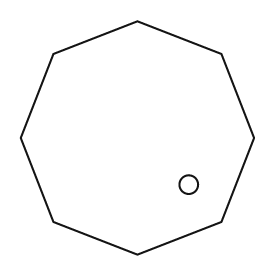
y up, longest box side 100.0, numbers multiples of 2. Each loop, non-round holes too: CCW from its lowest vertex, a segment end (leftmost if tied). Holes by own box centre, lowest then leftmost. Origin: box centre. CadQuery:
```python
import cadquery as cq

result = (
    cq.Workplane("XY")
    .moveTo(0.0, -50.0)
    .lineTo(36.0, -36.0)
    .lineTo(50.0, 0.0)
    .lineTo(36.0, 36.0)
    .lineTo(0.0, 50.0)
    .lineTo(-36.0, 36.0)
    .lineTo(-50.0, 0.0)
    .lineTo(-36.0, -36.0)
    .close()
    .moveTo(22.0, -20.0)
    .circle(4.0)
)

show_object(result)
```